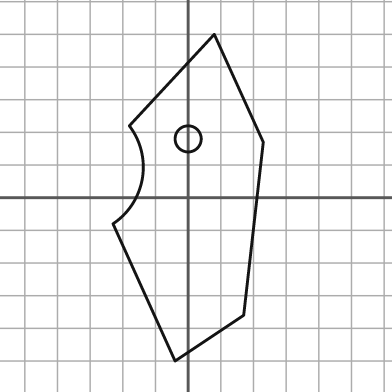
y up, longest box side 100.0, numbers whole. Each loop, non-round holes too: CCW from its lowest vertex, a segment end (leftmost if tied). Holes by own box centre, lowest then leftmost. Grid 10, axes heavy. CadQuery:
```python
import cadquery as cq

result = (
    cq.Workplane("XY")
    .moveTo(-4.0, -50.0)
    .lineTo(17.0, -36.0)
    .lineTo(23.0, 17.0)
    .lineTo(8.0, 50.0)
    .lineTo(-18.0, 22.0)
    .threePointArc((-14.0, 6.0), (-23.0, -8.0))
    .close()
    .moveTo(0.0, 18.0)
    .circle(4.0)
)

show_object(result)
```